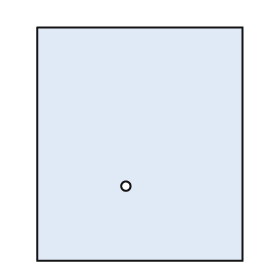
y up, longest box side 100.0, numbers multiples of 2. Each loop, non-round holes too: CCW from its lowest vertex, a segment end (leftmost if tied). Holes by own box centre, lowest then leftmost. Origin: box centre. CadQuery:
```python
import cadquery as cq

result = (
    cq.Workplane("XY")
    .moveTo(-44.0, -50.0)
    .lineTo(44.0, -50.0)
    .lineTo(44.0, 50.0)
    .lineTo(-44.0, 50.0)
    .close()
    .moveTo(-6.0, -18.0)
    .circle(2.0)
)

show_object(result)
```